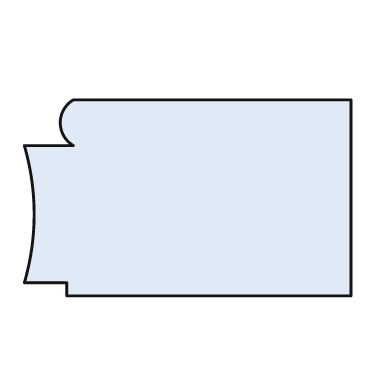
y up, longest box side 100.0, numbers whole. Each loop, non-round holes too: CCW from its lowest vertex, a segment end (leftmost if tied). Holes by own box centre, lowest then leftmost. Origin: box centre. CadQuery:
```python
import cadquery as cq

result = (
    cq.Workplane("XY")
    .moveTo(-37.0, -30.0)
    .lineTo(50.0, -30.0)
    .lineTo(50.0, 30.0)
    .lineTo(-35.0, 30.0)
    .threePointArc((-39.0, 23.0), (-35.0, 16.0))
    .lineTo(-50.0, 16.0)
    .threePointArc((-47.0, -5.0), (-50.0, -26.0))
    .lineTo(-37.0, -26.0)
    .close()
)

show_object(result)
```